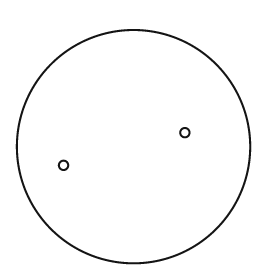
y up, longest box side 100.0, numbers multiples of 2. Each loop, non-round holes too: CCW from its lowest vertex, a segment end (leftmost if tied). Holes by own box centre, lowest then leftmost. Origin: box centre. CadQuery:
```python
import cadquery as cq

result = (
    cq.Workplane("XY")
    .moveTo(0.0, 0.0)
    .circle(50.0)
    .moveTo(-30.0, -8.0)
    .circle(2.0)
    .moveTo(22.0, 6.0)
    .circle(2.0)
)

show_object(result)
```